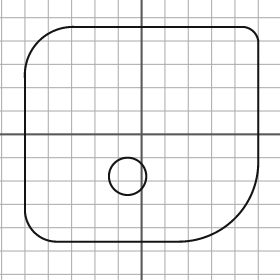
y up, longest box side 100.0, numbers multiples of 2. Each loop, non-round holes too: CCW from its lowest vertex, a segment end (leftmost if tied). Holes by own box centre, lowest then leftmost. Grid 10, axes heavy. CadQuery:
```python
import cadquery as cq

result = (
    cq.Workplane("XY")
    .moveTo(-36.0, -46.0)
    .lineTo(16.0, -46.0)
    .threePointArc((40.0, -36.0), (50.0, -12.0))
    .lineTo(50.0, 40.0)
    .threePointArc((48.0, 44.0), (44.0, 46.0))
    .lineTo(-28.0, 46.0)
    .threePointArc((-44.0, 40.0), (-50.0, 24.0))
    .lineTo(-50.0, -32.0)
    .threePointArc((-46.0, -42.0), (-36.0, -46.0))
    .close()
    .moveTo(-6.0, -18.0)
    .circle(8.0)
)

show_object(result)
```